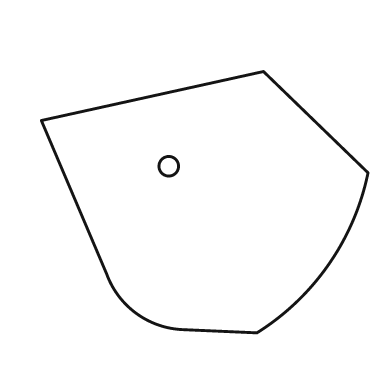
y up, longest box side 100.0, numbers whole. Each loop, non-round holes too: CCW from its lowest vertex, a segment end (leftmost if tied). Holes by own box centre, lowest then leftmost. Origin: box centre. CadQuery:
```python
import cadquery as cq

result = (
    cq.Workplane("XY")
    .moveTo(16.0, -40.0)
    .threePointArc((38.0, -19.0), (50.0, 9.0))
    .lineTo(18.0, 40.0)
    .lineTo(-50.0, 25.0)
    .lineTo(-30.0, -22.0)
    .threePointArc((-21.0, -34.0), (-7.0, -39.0))
    .close()
    .moveTo(-11.0, 11.0)
    .circle(3.0)
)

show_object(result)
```